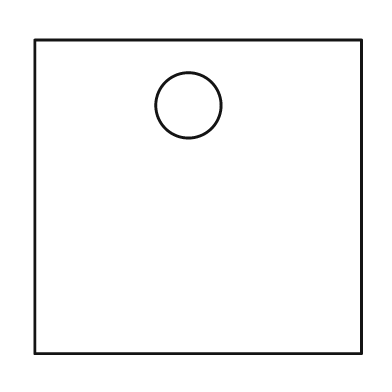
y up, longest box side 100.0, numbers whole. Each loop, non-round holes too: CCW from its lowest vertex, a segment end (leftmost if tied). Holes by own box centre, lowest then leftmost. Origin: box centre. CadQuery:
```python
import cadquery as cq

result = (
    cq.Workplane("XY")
    .moveTo(-50.0, -48.0)
    .lineTo(50.0, -48.0)
    .lineTo(50.0, 48.0)
    .lineTo(-50.0, 48.0)
    .close()
    .moveTo(-3.0, 28.0)
    .circle(10.0)
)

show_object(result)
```